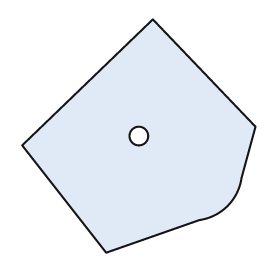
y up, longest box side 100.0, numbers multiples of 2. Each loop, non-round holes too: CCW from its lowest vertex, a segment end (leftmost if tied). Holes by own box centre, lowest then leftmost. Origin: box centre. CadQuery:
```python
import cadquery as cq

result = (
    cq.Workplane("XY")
    .moveTo(-14.0, -50.0)
    .lineTo(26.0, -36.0)
    .threePointArc((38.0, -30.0), (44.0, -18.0))
    .lineTo(50.0, 4.0)
    .lineTo(6.0, 50.0)
    .lineTo(-50.0, -4.0)
    .close()
    .moveTo(0.0, 0.0)
    .circle(4.0)
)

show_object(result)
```